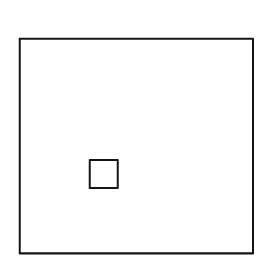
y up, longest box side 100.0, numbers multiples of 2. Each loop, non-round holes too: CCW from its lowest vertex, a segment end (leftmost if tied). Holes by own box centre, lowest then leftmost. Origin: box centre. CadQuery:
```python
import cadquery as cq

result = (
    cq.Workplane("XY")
    .moveTo(-50.0, -46.0)
    .lineTo(50.0, -46.0)
    .lineTo(50.0, 46.0)
    .lineTo(-50.0, 46.0)
    .close()
    .moveTo(-20.0, -18.0)
    .lineTo(-8.0, -18.0)
    .lineTo(-8.0, -6.0)
    .lineTo(-20.0, -6.0)
    .close()
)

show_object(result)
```